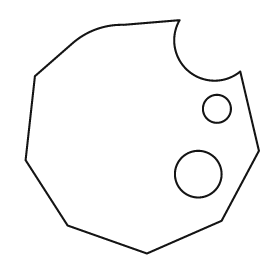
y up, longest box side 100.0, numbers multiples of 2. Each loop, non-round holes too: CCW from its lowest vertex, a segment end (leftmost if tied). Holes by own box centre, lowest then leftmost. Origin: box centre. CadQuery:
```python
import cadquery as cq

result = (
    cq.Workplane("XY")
    .moveTo(2.0, -50.0)
    .lineTo(34.0, -36.0)
    .lineTo(50.0, -6.0)
    .lineTo(42.0, 28.0)
    .threePointArc((20.0, 28.0), (16.0, 50.0))
    .lineTo(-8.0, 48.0)
    .threePointArc((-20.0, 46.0), (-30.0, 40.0))
    .lineTo(-46.0, 26.0)
    .lineTo(-50.0, -10.0)
    .lineTo(-32.0, -38.0)
    .close()
    .moveTo(24.0, -16.0)
    .circle(10.0)
    .moveTo(32.0, 12.0)
    .circle(6.0)
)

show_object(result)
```